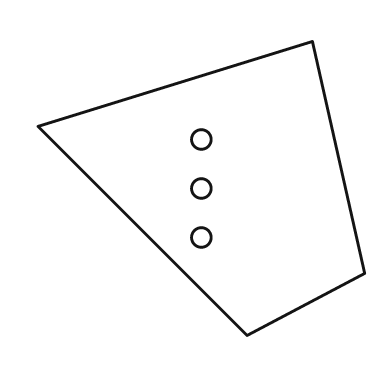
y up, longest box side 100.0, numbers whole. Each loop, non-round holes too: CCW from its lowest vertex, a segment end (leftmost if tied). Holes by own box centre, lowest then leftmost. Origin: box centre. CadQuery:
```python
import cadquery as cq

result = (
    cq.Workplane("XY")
    .moveTo(14.0, -45.0)
    .lineTo(50.0, -26.0)
    .lineTo(34.0, 45.0)
    .lineTo(-50.0, 19.0)
    .close()
    .moveTo(0.0, -15.0)
    .circle(3.0)
    .moveTo(0.0, 0.0)
    .circle(3.0)
    .moveTo(0.0, 15.0)
    .circle(3.0)
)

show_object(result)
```